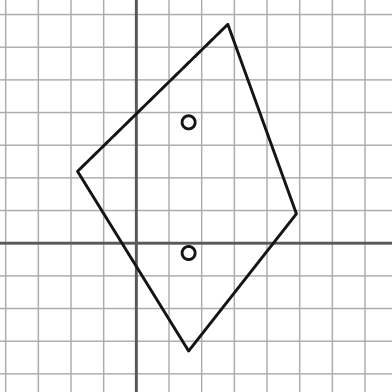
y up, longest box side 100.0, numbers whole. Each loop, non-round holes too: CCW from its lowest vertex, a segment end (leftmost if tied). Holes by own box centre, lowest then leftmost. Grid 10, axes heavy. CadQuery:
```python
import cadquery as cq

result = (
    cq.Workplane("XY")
    .moveTo(16.0, -33.0)
    .lineTo(49.0, 9.0)
    .lineTo(28.0, 67.0)
    .lineTo(-18.0, 22.0)
    .close()
    .moveTo(16.0, -3.0)
    .circle(2.0)
    .moveTo(16.0, 37.0)
    .circle(2.0)
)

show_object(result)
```